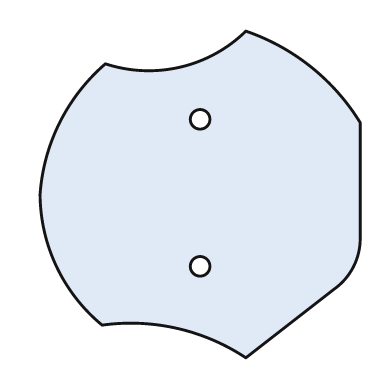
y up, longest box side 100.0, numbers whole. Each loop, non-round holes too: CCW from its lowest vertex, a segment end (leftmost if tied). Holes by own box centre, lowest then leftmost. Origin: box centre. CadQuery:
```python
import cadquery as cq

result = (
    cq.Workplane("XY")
    .moveTo(14.0, -50.0)
    .lineTo(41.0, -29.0)
    .threePointArc((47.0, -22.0), (49.0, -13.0))
    .lineTo(49.0, 22.0)
    .threePointArc((34.0, 39.0), (14.0, 50.0))
    .threePointArc((-6.0, 39.0), (-29.0, 40.0))
    .threePointArc((-43.0, 22.0), (-49.0, 0.0))
    .threePointArc((-44.0, -22.0), (-30.0, -40.0))
    .threePointArc((-7.0, -41.0), (14.0, -50.0))
    .close()
    .moveTo(0.0, -22.0)
    .circle(3.0)
    .moveTo(0.0, 23.0)
    .circle(3.0)
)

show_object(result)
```